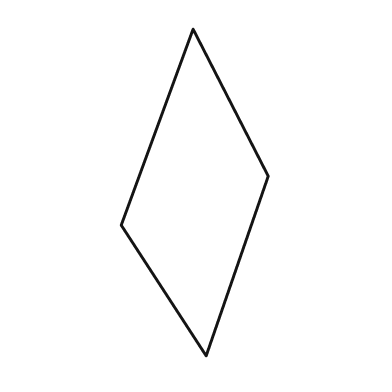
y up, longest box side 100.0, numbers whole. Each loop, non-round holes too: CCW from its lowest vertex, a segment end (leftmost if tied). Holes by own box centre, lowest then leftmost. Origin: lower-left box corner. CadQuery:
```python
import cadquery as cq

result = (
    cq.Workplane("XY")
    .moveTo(26.0, 0.0)
    .lineTo(45.0, 55.0)
    .lineTo(22.0, 100.0)
    .lineTo(0.0, 40.0)
    .close()
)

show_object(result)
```